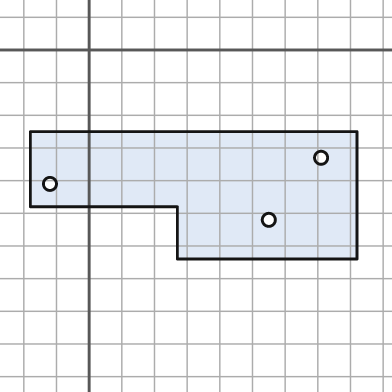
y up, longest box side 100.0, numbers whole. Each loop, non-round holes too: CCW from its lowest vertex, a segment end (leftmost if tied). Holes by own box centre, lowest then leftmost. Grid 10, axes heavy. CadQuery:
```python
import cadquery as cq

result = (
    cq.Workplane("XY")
    .moveTo(27.0, -64.0)
    .lineTo(82.0, -64.0)
    .lineTo(82.0, -25.0)
    .lineTo(-18.0, -25.0)
    .lineTo(-18.0, -48.0)
    .lineTo(27.0, -48.0)
    .close()
    .moveTo(55.0, -52.0)
    .circle(2.0)
    .moveTo(-12.0, -41.0)
    .circle(2.0)
    .moveTo(71.0, -33.0)
    .circle(2.0)
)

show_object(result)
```